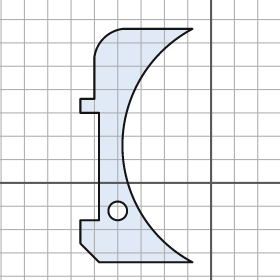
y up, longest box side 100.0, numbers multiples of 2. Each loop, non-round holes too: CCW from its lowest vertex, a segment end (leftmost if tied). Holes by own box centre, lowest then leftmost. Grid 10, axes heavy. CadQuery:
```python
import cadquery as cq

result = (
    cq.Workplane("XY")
    .moveTo(-48.0, -34.0)
    .lineTo(-8.0, -34.0)
    .threePointArc((-38.0, 16.0), (-8.0, 66.0))
    .lineTo(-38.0, 66.0)
    .threePointArc((-46.0, 62.0), (-50.0, 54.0))
    .lineTo(-50.0, 36.0)
    .lineTo(-56.0, 36.0)
    .lineTo(-56.0, 30.0)
    .lineTo(-48.0, 30.0)
    .lineTo(-48.0, -16.0)
    .lineTo(-56.0, -16.0)
    .lineTo(-56.0, -26.0)
    .close()
    .moveTo(-40.0, -12.0)
    .circle(4.0)
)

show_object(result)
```